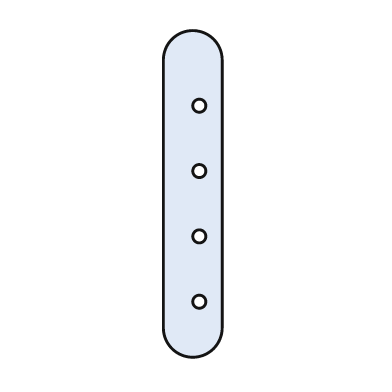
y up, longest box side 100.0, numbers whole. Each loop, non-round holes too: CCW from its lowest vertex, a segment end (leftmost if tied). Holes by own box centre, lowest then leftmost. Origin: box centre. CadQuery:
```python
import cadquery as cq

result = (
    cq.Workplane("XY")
    .moveTo(-9.0, -41.0)
    .threePointArc((0.0, -50.0), (9.0, -41.0))
    .lineTo(9.0, 41.0)
    .threePointArc((0.0, 50.0), (-9.0, 41.0))
    .close()
    .moveTo(2.0, -33.0)
    .circle(2.0)
    .moveTo(2.0, -13.0)
    .circle(2.0)
    .moveTo(2.0, 7.0)
    .circle(2.0)
    .moveTo(2.0, 27.0)
    .circle(2.0)
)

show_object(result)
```